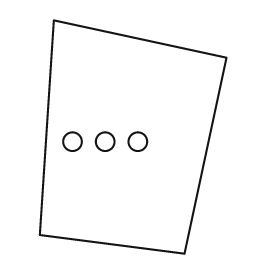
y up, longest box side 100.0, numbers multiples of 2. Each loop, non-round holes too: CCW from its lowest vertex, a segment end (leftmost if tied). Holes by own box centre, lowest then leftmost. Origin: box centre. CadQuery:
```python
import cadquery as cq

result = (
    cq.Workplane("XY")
    .moveTo(22.0, -50.0)
    .lineTo(40.0, 34.0)
    .lineTo(-34.0, 50.0)
    .lineTo(-40.0, -42.0)
    .close()
    .moveTo(-26.0, -2.0)
    .circle(4.0)
    .moveTo(-12.0, -2.0)
    .circle(4.0)
    .moveTo(2.0, -2.0)
    .circle(4.0)
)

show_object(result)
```